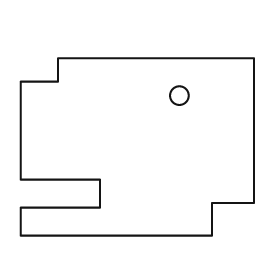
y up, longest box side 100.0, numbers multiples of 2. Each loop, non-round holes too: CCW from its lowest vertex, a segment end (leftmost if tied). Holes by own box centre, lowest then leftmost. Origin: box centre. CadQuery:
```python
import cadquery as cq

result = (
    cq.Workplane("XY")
    .moveTo(-50.0, -38.0)
    .lineTo(32.0, -38.0)
    .lineTo(32.0, -24.0)
    .lineTo(50.0, -24.0)
    .lineTo(50.0, 38.0)
    .lineTo(-34.0, 38.0)
    .lineTo(-34.0, 28.0)
    .lineTo(-50.0, 28.0)
    .lineTo(-50.0, -14.0)
    .lineTo(-16.0, -14.0)
    .lineTo(-16.0, -26.0)
    .lineTo(-50.0, -26.0)
    .close()
    .moveTo(18.0, 22.0)
    .circle(4.0)
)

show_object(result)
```